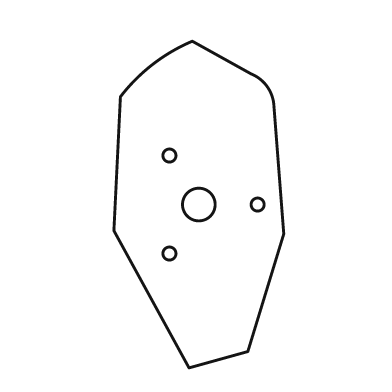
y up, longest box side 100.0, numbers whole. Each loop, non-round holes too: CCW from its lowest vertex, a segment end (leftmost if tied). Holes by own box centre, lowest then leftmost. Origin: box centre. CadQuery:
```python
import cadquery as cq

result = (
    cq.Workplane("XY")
    .moveTo(-3.0, -50.0)
    .lineTo(15.0, -45.0)
    .lineTo(26.0, -9.0)
    .lineTo(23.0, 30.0)
    .threePointArc((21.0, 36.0), (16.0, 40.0))
    .lineTo(-2.0, 50.0)
    .threePointArc((-14.0, 43.0), (-24.0, 33.0))
    .lineTo(-26.0, -8.0)
    .close()
    .moveTo(-9.0, -15.0)
    .circle(2.0)
    .moveTo(0.0, 0.0)
    .circle(5.0)
    .moveTo(18.0, 0.0)
    .circle(2.0)
    .moveTo(-9.0, 15.0)
    .circle(2.0)
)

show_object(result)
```